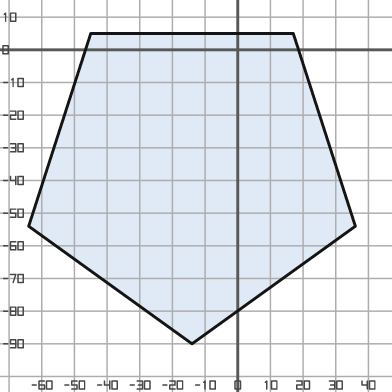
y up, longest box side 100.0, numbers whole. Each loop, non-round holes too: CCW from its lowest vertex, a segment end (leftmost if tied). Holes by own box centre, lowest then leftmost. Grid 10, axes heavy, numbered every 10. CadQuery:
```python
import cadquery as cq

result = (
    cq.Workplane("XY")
    .moveTo(-14.0, -90.0)
    .lineTo(36.0, -54.0)
    .lineTo(17.0, 5.0)
    .lineTo(-45.0, 5.0)
    .lineTo(-64.0, -54.0)
    .close()
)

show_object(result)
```